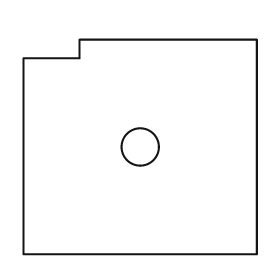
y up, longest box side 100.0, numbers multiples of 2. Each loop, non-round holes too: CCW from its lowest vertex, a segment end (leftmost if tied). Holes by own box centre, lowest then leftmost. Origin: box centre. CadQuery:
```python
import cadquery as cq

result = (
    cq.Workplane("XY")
    .moveTo(-50.0, -46.0)
    .lineTo(50.0, -46.0)
    .lineTo(50.0, 46.0)
    .lineTo(-26.0, 46.0)
    .lineTo(-26.0, 38.0)
    .lineTo(-50.0, 38.0)
    .close()
    .moveTo(0.0, 0.0)
    .circle(8.0)
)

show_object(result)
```